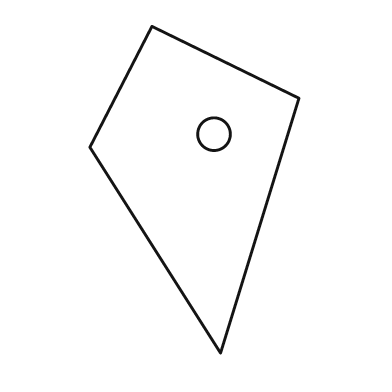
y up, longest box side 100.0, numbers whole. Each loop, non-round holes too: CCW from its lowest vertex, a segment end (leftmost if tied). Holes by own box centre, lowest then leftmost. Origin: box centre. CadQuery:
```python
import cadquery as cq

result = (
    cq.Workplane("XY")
    .moveTo(8.0, -50.0)
    .lineTo(32.0, 28.0)
    .lineTo(-13.0, 50.0)
    .lineTo(-32.0, 13.0)
    .close()
    .moveTo(6.0, 17.0)
    .circle(5.0)
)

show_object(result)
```